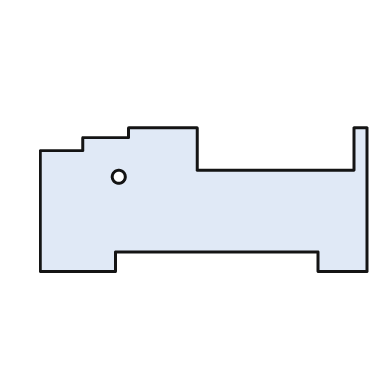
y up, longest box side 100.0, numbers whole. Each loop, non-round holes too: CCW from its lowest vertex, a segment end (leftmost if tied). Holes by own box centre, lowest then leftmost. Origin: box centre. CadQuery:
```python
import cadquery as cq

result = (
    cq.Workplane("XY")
    .moveTo(-50.0, -22.0)
    .lineTo(-27.0, -22.0)
    .lineTo(-27.0, -16.0)
    .lineTo(35.0, -16.0)
    .lineTo(35.0, -22.0)
    .lineTo(50.0, -22.0)
    .lineTo(50.0, 22.0)
    .lineTo(46.0, 22.0)
    .lineTo(46.0, 9.0)
    .lineTo(-2.0, 9.0)
    .lineTo(-2.0, 22.0)
    .lineTo(-23.0, 22.0)
    .lineTo(-23.0, 19.0)
    .lineTo(-37.0, 19.0)
    .lineTo(-37.0, 15.0)
    .lineTo(-50.0, 15.0)
    .close()
    .moveTo(-26.0, 7.0)
    .circle(2.0)
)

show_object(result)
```